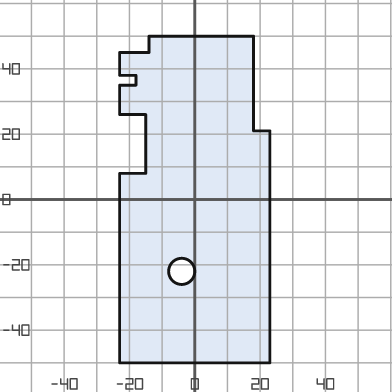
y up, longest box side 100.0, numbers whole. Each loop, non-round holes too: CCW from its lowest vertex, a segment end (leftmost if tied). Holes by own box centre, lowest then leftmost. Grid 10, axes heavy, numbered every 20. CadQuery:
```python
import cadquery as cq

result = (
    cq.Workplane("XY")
    .moveTo(-23.0, -50.0)
    .lineTo(23.0, -50.0)
    .lineTo(23.0, 21.0)
    .lineTo(18.0, 21.0)
    .lineTo(18.0, 50.0)
    .lineTo(-14.0, 50.0)
    .lineTo(-14.0, 45.0)
    .lineTo(-23.0, 45.0)
    .lineTo(-23.0, 38.0)
    .lineTo(-18.0, 38.0)
    .lineTo(-18.0, 35.0)
    .lineTo(-23.0, 35.0)
    .lineTo(-23.0, 26.0)
    .lineTo(-15.0, 26.0)
    .lineTo(-15.0, 8.0)
    .lineTo(-23.0, 8.0)
    .close()
    .moveTo(-4.0, -22.0)
    .circle(4.0)
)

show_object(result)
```